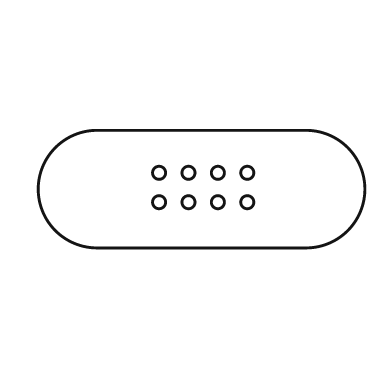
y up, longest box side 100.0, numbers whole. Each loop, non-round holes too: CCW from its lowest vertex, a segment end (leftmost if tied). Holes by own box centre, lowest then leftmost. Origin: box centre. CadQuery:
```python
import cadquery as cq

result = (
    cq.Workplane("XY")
    .moveTo(-32.0, -18.0)
    .lineTo(32.0, -18.0)
    .threePointArc((50.0, 0.0), (32.0, 18.0))
    .lineTo(-32.0, 18.0)
    .threePointArc((-50.0, 0.0), (-32.0, -18.0))
    .close()
    .moveTo(-13.0, -4.0)
    .circle(2.0)
    .moveTo(-4.0, -4.0)
    .circle(2.0)
    .moveTo(5.0, -4.0)
    .circle(2.0)
    .moveTo(14.0, -4.0)
    .circle(2.0)
    .moveTo(-13.0, 5.0)
    .circle(2.0)
    .moveTo(-4.0, 5.0)
    .circle(2.0)
    .moveTo(5.0, 5.0)
    .circle(2.0)
    .moveTo(14.0, 5.0)
    .circle(2.0)
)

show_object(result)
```